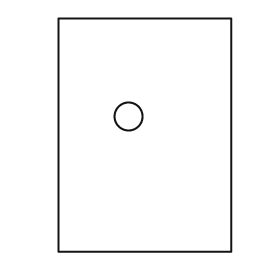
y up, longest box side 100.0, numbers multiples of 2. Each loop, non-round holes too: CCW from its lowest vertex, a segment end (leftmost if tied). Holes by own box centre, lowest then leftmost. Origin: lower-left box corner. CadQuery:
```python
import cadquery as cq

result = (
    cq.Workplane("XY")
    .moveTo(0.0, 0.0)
    .lineTo(74.0, 0.0)
    .lineTo(74.0, 100.0)
    .lineTo(0.0, 100.0)
    .close()
    .moveTo(30.0, 58.0)
    .circle(6.0)
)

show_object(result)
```